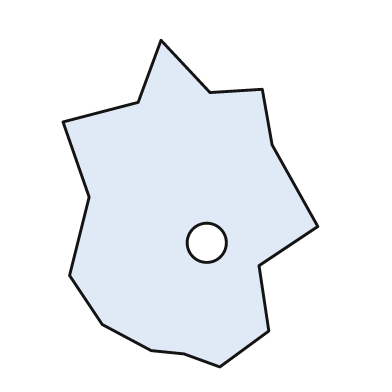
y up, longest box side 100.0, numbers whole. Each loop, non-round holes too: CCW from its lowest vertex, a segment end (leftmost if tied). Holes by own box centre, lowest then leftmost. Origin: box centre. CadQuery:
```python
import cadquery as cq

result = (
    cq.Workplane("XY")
    .moveTo(9.0, -50.0)
    .lineTo(24.0, -39.0)
    .lineTo(21.0, -19.0)
    .lineTo(39.0, -7.0)
    .lineTo(25.0, 18.0)
    .lineTo(22.0, 35.0)
    .lineTo(6.0, 34.0)
    .lineTo(-9.0, 50.0)
    .lineTo(-16.0, 31.0)
    .lineTo(-39.0, 25.0)
    .lineTo(-31.0, 2.0)
    .lineTo(-37.0, -22.0)
    .lineTo(-27.0, -37.0)
    .lineTo(-12.0, -45.0)
    .lineTo(-2.0, -46.0)
    .close()
    .moveTo(5.0, -12.0)
    .circle(6.0)
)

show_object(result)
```